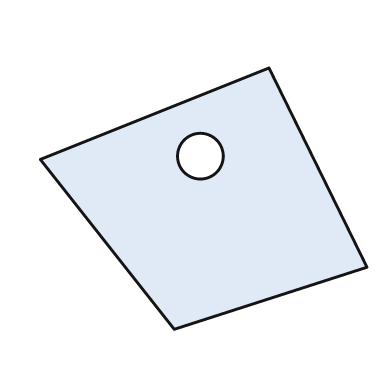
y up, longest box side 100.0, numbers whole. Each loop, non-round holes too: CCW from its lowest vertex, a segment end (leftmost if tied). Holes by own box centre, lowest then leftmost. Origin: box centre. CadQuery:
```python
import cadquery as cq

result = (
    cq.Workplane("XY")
    .moveTo(-9.0, -40.0)
    .lineTo(50.0, -21.0)
    .lineTo(20.0, 40.0)
    .lineTo(-50.0, 12.0)
    .close()
    .moveTo(-1.0, 13.0)
    .circle(7.0)
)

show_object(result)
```